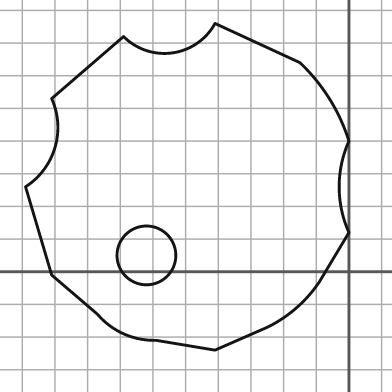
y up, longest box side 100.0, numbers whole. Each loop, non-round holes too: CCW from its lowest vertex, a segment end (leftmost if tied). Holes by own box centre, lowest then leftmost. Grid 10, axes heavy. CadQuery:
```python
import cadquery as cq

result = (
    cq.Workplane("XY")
    .moveTo(-41.0, -24.0)
    .lineTo(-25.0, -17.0)
    .threePointArc((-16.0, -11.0), (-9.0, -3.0))
    .lineTo(0.0, 12.0)
    .threePointArc((-3.0, 26.0), (0.0, 40.0))
    .threePointArc((-6.0, 53.0), (-15.0, 64.0))
    .lineTo(-41.0, 76.0)
    .threePointArc((-54.0, 67.0), (-69.0, 72.0))
    .lineTo(-91.0, 53.0)
    .threePointArc((-90.0, 38.0), (-99.0, 26.0))
    .lineTo(-91.0, -1.0)
    .lineTo(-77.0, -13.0)
    .threePointArc((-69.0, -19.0), (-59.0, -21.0))
    .close()
    .moveTo(-62.0, 5.0)
    .circle(9.0)
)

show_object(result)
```